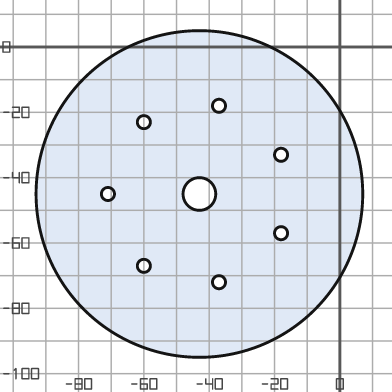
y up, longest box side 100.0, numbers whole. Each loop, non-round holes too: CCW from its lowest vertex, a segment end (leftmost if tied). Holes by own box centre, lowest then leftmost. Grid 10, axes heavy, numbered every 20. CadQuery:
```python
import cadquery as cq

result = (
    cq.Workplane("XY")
    .moveTo(-43.0, -45.0)
    .circle(50.0)
    .moveTo(-37.0, -72.0)
    .circle(2.0)
    .moveTo(-60.0, -67.0)
    .circle(2.0)
    .moveTo(-18.0, -57.0)
    .circle(2.0)
    .moveTo(-71.0, -45.0)
    .circle(2.0)
    .moveTo(-43.0, -45.0)
    .circle(5.0)
    .moveTo(-18.0, -33.0)
    .circle(2.0)
    .moveTo(-60.0, -23.0)
    .circle(2.0)
    .moveTo(-37.0, -18.0)
    .circle(2.0)
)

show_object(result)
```